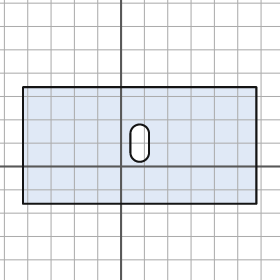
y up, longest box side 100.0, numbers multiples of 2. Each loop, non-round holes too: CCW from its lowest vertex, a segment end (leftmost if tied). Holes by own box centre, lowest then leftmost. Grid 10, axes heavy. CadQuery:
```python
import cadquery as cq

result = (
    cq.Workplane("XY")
    .moveTo(-42.0, -16.0)
    .lineTo(58.0, -16.0)
    .lineTo(58.0, 34.0)
    .lineTo(-42.0, 34.0)
    .close()
    .moveTo(4.0, 6.0)
    .threePointArc((8.0, 2.0), (12.0, 6.0))
    .lineTo(12.0, 14.0)
    .threePointArc((8.0, 18.0), (4.0, 14.0))
    .close()
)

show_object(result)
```